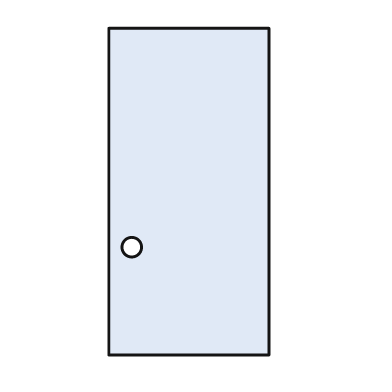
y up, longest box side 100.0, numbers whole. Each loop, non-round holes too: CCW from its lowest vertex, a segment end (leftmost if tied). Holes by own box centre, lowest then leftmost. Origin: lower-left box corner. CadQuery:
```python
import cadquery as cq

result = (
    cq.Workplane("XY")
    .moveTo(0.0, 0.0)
    .lineTo(49.0, 0.0)
    .lineTo(49.0, 100.0)
    .lineTo(0.0, 100.0)
    .close()
    .moveTo(7.0, 33.0)
    .circle(3.0)
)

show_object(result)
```